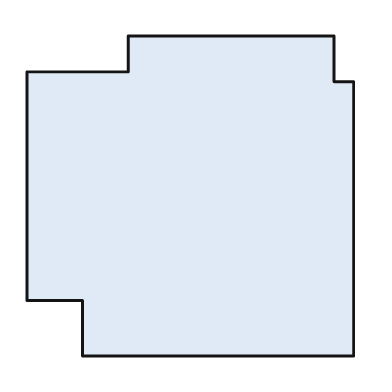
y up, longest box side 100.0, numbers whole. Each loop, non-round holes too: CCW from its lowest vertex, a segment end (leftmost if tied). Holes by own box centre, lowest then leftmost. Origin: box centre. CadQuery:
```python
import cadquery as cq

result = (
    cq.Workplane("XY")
    .moveTo(-33.0, -49.0)
    .lineTo(50.0, -49.0)
    .lineTo(50.0, 35.0)
    .lineTo(44.0, 35.0)
    .lineTo(44.0, 49.0)
    .lineTo(-19.0, 49.0)
    .lineTo(-19.0, 38.0)
    .lineTo(-50.0, 38.0)
    .lineTo(-50.0, -32.0)
    .lineTo(-33.0, -32.0)
    .close()
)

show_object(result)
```